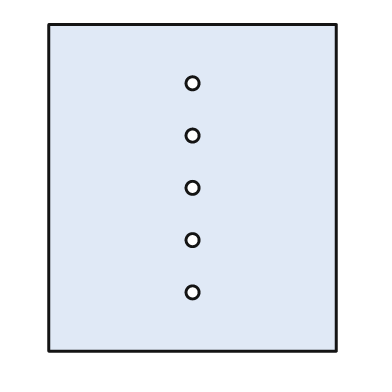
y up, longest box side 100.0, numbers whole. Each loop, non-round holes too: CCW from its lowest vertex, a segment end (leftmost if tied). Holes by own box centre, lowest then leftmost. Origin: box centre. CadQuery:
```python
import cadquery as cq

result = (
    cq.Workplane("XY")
    .moveTo(-44.0, -50.0)
    .lineTo(44.0, -50.0)
    .lineTo(44.0, 50.0)
    .lineTo(-44.0, 50.0)
    .close()
    .moveTo(0.0, -32.0)
    .circle(2.0)
    .moveTo(0.0, -16.0)
    .circle(2.0)
    .moveTo(0.0, 0.0)
    .circle(2.0)
    .moveTo(0.0, 16.0)
    .circle(2.0)
    .moveTo(0.0, 32.0)
    .circle(2.0)
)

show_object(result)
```